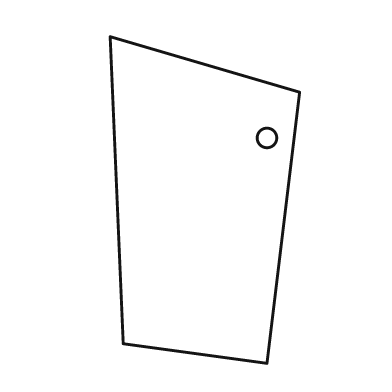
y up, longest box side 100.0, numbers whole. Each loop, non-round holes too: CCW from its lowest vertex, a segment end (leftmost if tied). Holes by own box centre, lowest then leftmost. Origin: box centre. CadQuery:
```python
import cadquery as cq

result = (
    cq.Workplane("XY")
    .moveTo(19.0, -50.0)
    .lineTo(29.0, 33.0)
    .lineTo(-29.0, 50.0)
    .lineTo(-25.0, -44.0)
    .close()
    .moveTo(19.0, 19.0)
    .circle(3.0)
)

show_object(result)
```